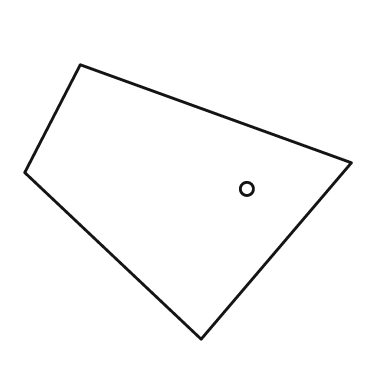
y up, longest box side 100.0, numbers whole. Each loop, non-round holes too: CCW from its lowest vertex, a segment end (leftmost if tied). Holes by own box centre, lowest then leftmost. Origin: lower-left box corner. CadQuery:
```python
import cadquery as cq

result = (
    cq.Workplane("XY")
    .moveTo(54.0, 0.0)
    .lineTo(100.0, 54.0)
    .lineTo(17.0, 84.0)
    .lineTo(0.0, 51.0)
    .close()
    .moveTo(68.0, 46.0)
    .circle(2.0)
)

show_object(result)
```